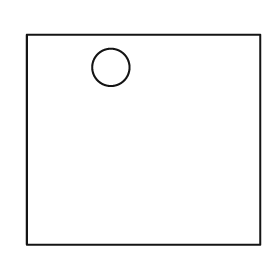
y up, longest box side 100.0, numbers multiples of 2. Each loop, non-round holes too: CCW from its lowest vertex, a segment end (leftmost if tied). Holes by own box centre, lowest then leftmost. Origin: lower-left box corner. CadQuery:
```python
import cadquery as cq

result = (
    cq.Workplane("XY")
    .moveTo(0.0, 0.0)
    .lineTo(100.0, 0.0)
    .lineTo(100.0, 90.0)
    .lineTo(0.0, 90.0)
    .close()
    .moveTo(36.0, 76.0)
    .circle(8.0)
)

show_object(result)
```